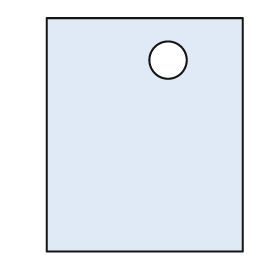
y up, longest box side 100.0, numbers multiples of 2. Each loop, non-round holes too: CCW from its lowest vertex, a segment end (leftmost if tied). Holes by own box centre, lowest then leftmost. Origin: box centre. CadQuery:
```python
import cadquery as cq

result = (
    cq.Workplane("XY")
    .moveTo(-42.0, -50.0)
    .lineTo(42.0, -50.0)
    .lineTo(42.0, 50.0)
    .lineTo(-42.0, 50.0)
    .close()
    .moveTo(10.0, 32.0)
    .circle(8.0)
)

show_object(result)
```